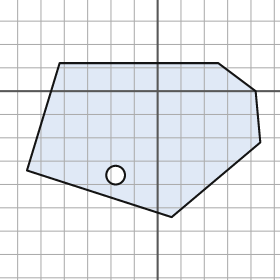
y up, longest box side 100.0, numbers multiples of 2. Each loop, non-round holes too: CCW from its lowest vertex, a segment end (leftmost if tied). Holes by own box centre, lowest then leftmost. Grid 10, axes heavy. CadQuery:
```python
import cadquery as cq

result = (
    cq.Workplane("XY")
    .moveTo(6.0, -54.0)
    .lineTo(44.0, -22.0)
    .lineTo(42.0, 0.0)
    .lineTo(26.0, 12.0)
    .lineTo(-42.0, 12.0)
    .lineTo(-56.0, -34.0)
    .close()
    .moveTo(-18.0, -36.0)
    .circle(4.0)
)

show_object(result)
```